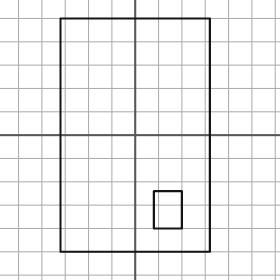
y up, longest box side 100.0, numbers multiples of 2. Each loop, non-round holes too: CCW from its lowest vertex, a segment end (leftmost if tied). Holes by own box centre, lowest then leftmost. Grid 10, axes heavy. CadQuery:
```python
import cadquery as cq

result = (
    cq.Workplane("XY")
    .moveTo(-32.0, -50.0)
    .lineTo(32.0, -50.0)
    .lineTo(32.0, 50.0)
    .lineTo(-32.0, 50.0)
    .close()
    .moveTo(8.0, -40.0)
    .lineTo(20.0, -40.0)
    .lineTo(20.0, -24.0)
    .lineTo(8.0, -24.0)
    .close()
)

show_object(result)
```